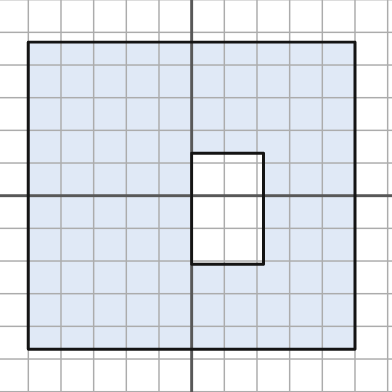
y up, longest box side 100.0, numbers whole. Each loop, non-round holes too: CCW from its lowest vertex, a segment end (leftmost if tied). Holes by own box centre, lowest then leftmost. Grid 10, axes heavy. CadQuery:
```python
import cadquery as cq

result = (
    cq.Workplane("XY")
    .moveTo(-50.0, -47.0)
    .lineTo(50.0, -47.0)
    .lineTo(50.0, 47.0)
    .lineTo(-50.0, 47.0)
    .close()
    .moveTo(0.0, -21.0)
    .lineTo(22.0, -21.0)
    .lineTo(22.0, 13.0)
    .lineTo(0.0, 13.0)
    .close()
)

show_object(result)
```